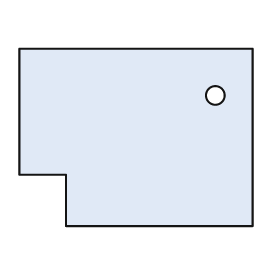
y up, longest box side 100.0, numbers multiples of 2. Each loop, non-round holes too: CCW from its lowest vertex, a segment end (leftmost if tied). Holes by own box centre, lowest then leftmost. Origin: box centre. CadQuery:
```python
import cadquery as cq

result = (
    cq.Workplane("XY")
    .moveTo(-30.0, -38.0)
    .lineTo(50.0, -38.0)
    .lineTo(50.0, 38.0)
    .lineTo(-50.0, 38.0)
    .lineTo(-50.0, -16.0)
    .lineTo(-30.0, -16.0)
    .close()
    .moveTo(34.0, 18.0)
    .circle(4.0)
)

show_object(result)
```